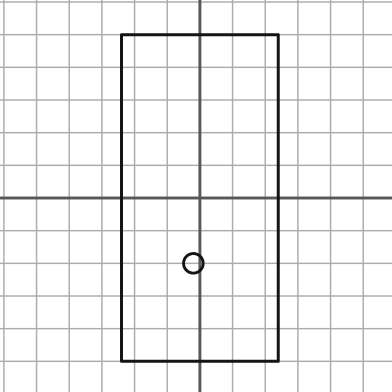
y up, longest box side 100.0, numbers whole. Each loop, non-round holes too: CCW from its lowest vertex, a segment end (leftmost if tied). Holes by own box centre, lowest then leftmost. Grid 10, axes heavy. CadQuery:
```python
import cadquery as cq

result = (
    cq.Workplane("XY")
    .moveTo(-24.0, -50.0)
    .lineTo(24.0, -50.0)
    .lineTo(24.0, 50.0)
    .lineTo(-24.0, 50.0)
    .close()
    .moveTo(-2.0, -20.0)
    .circle(3.0)
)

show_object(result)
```